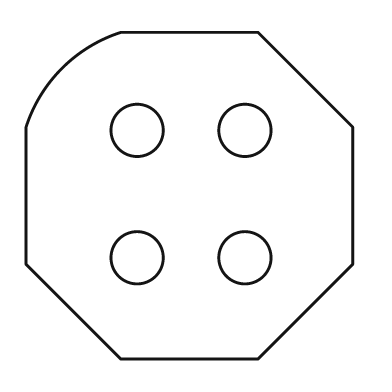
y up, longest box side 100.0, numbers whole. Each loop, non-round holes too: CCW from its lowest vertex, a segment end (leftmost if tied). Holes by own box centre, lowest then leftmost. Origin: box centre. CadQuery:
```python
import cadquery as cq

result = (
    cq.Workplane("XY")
    .moveTo(-21.0, -50.0)
    .lineTo(21.0, -50.0)
    .lineTo(50.0, -21.0)
    .lineTo(50.0, 21.0)
    .lineTo(21.0, 50.0)
    .lineTo(-21.0, 50.0)
    .threePointArc((-39.0, 39.0), (-50.0, 21.0))
    .lineTo(-50.0, -21.0)
    .close()
    .moveTo(-16.0, -19.0)
    .circle(8.0)
    .moveTo(17.0, -19.0)
    .circle(8.0)
    .moveTo(-16.0, 20.0)
    .circle(8.0)
    .moveTo(17.0, 20.0)
    .circle(8.0)
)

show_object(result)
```